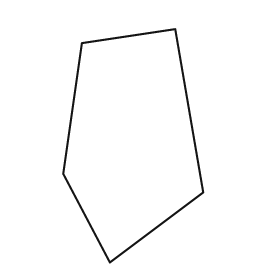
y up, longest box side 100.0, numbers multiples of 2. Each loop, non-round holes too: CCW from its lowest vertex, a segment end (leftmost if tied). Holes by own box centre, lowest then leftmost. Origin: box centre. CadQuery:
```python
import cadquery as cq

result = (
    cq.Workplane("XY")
    .moveTo(-10.0, -50.0)
    .lineTo(30.0, -20.0)
    .lineTo(18.0, 50.0)
    .lineTo(-22.0, 44.0)
    .lineTo(-30.0, -12.0)
    .close()
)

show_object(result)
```